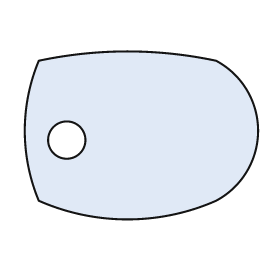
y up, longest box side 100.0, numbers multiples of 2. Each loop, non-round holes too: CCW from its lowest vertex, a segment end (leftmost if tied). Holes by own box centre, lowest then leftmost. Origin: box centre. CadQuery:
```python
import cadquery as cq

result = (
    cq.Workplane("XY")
    .moveTo(-44.0, -28.0)
    .threePointArc((-6.0, -36.0), (32.0, -28.0))
    .threePointArc((50.0, 2.0), (32.0, 32.0))
    .threePointArc((-6.0, 36.0), (-44.0, 32.0))
    .threePointArc((-50.0, 2.0), (-44.0, -28.0))
    .close()
    .moveTo(-32.0, -2.0)
    .circle(8.0)
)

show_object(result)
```